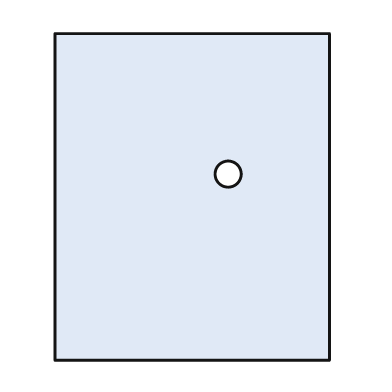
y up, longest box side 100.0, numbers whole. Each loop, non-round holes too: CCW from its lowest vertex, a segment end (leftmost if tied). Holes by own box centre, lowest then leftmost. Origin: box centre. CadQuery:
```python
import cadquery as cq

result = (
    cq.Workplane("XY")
    .moveTo(-42.0, -50.0)
    .lineTo(42.0, -50.0)
    .lineTo(42.0, 50.0)
    .lineTo(-42.0, 50.0)
    .close()
    .moveTo(11.0, 7.0)
    .circle(4.0)
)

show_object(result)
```